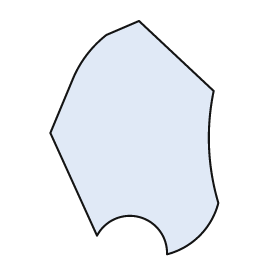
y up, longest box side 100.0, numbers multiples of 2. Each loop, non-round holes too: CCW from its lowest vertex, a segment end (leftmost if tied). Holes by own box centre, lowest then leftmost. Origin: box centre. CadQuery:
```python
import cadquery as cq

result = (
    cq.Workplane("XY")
    .moveTo(14.0, -50.0)
    .threePointArc((28.0, -42.0), (36.0, -28.0))
    .threePointArc((32.0, -4.0), (34.0, 20.0))
    .lineTo(2.0, 50.0)
    .lineTo(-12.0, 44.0)
    .threePointArc((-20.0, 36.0), (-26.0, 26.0))
    .lineTo(-36.0, 2.0)
    .lineTo(-16.0, -42.0)
    .threePointArc((2.0, -34.0), (14.0, -50.0))
    .close()
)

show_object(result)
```